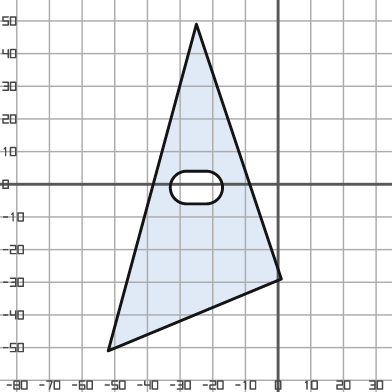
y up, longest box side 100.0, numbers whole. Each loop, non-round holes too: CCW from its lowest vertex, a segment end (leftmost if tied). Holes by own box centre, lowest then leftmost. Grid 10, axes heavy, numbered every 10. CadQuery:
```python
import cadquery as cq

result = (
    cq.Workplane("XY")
    .moveTo(-52.0, -51.0)
    .lineTo(1.0, -29.0)
    .lineTo(-25.0, 49.0)
    .close()
    .moveTo(-28.0, -6.0)
    .lineTo(-22.0, -6.0)
    .threePointArc((-17.0, -1.0), (-22.0, 4.0))
    .lineTo(-28.0, 4.0)
    .threePointArc((-33.0, -1.0), (-28.0, -6.0))
    .close()
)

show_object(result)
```